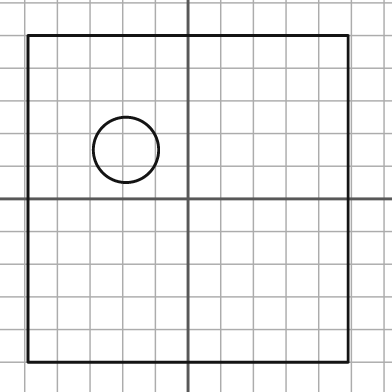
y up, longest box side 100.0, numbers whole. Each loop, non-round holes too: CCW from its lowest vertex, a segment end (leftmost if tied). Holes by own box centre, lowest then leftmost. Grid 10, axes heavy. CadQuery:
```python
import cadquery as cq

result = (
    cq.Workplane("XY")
    .moveTo(-49.0, -50.0)
    .lineTo(49.0, -50.0)
    .lineTo(49.0, 50.0)
    .lineTo(-49.0, 50.0)
    .close()
    .moveTo(-19.0, 15.0)
    .circle(10.0)
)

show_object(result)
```